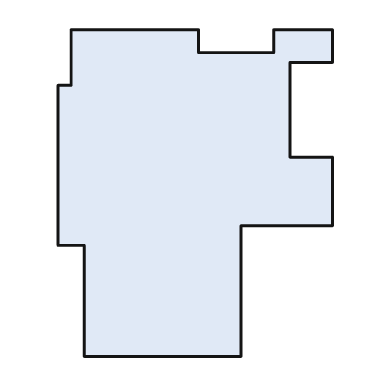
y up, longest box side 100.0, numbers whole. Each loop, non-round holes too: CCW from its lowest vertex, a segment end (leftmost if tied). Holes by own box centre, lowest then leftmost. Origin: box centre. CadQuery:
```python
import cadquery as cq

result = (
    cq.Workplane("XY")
    .moveTo(-34.0, -50.0)
    .lineTo(14.0, -50.0)
    .lineTo(14.0, -10.0)
    .lineTo(42.0, -10.0)
    .lineTo(42.0, 11.0)
    .lineTo(29.0, 11.0)
    .lineTo(29.0, 40.0)
    .lineTo(42.0, 40.0)
    .lineTo(42.0, 50.0)
    .lineTo(24.0, 50.0)
    .lineTo(24.0, 43.0)
    .lineTo(1.0, 43.0)
    .lineTo(1.0, 50.0)
    .lineTo(-38.0, 50.0)
    .lineTo(-38.0, 33.0)
    .lineTo(-42.0, 33.0)
    .lineTo(-42.0, -16.0)
    .lineTo(-34.0, -16.0)
    .close()
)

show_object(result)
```